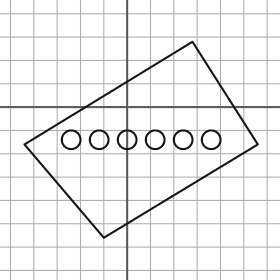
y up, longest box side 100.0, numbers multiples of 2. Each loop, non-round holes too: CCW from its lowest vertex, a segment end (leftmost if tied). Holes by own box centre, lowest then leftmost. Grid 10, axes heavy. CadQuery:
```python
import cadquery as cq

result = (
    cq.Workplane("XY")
    .moveTo(-10.0, -56.0)
    .lineTo(56.0, -16.0)
    .lineTo(28.0, 28.0)
    .lineTo(-44.0, -16.0)
    .close()
    .moveTo(-24.0, -14.0)
    .circle(4.0)
    .moveTo(-12.0, -14.0)
    .circle(4.0)
    .moveTo(0.0, -14.0)
    .circle(4.0)
    .moveTo(12.0, -14.0)
    .circle(4.0)
    .moveTo(24.0, -14.0)
    .circle(4.0)
    .moveTo(36.0, -14.0)
    .circle(4.0)
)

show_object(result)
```